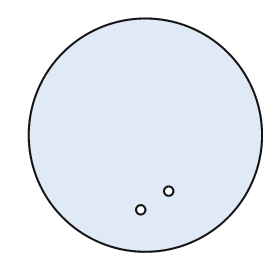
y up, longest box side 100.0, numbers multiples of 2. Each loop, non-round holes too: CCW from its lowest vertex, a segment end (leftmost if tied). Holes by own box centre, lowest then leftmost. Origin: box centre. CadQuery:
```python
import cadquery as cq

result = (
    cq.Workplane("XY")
    .moveTo(0.0, 0.0)
    .circle(50.0)
    .moveTo(-2.0, -32.0)
    .circle(2.0)
    .moveTo(10.0, -24.0)
    .circle(2.0)
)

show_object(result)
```